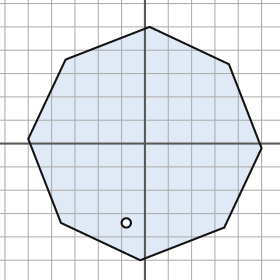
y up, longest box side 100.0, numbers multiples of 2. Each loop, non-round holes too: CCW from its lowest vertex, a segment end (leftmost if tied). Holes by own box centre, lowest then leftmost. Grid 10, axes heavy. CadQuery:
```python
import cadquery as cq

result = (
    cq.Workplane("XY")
    .moveTo(-2.0, -50.0)
    .lineTo(34.0, -36.0)
    .lineTo(50.0, -2.0)
    .lineTo(36.0, 34.0)
    .lineTo(2.0, 50.0)
    .lineTo(-34.0, 36.0)
    .lineTo(-50.0, 2.0)
    .lineTo(-36.0, -34.0)
    .close()
    .moveTo(-8.0, -34.0)
    .circle(2.0)
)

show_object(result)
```